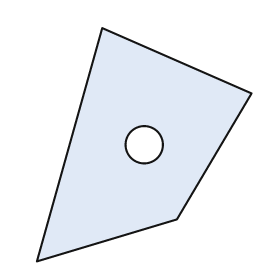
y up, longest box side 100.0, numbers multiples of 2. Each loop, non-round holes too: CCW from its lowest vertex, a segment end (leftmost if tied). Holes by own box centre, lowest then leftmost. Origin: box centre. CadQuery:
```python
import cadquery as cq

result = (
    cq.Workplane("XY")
    .moveTo(-46.0, -50.0)
    .lineTo(14.0, -32.0)
    .lineTo(46.0, 22.0)
    .lineTo(-18.0, 50.0)
    .close()
    .moveTo(0.0, 0.0)
    .circle(8.0)
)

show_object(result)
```